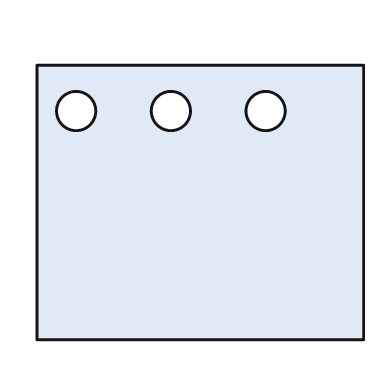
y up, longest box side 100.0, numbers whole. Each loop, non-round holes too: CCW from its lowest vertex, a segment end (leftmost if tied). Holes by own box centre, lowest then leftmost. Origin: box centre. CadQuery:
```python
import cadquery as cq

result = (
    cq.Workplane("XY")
    .moveTo(-50.0, -42.0)
    .lineTo(50.0, -42.0)
    .lineTo(50.0, 42.0)
    .lineTo(-50.0, 42.0)
    .close()
    .moveTo(-38.0, 28.0)
    .circle(6.0)
    .moveTo(-9.0, 28.0)
    .circle(6.0)
    .moveTo(20.0, 28.0)
    .circle(6.0)
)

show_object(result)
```